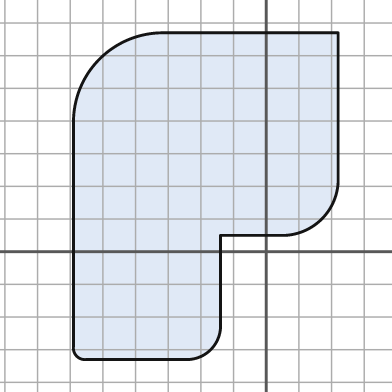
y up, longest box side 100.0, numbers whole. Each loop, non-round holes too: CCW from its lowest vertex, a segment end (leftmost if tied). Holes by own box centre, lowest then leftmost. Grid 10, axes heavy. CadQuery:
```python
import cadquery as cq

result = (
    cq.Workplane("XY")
    .moveTo(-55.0, -33.0)
    .lineTo(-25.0, -33.0)
    .threePointArc((-17.0, -30.0), (-14.0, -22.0))
    .lineTo(-14.0, 5.0)
    .lineTo(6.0, 5.0)
    .threePointArc((17.0, 10.0), (22.0, 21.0))
    .lineTo(22.0, 67.0)
    .lineTo(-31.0, 67.0)
    .threePointArc((-51.0, 59.0), (-59.0, 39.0))
    .lineTo(-59.0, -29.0)
    .threePointArc((-58.0, -32.0), (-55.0, -33.0))
    .close()
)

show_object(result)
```